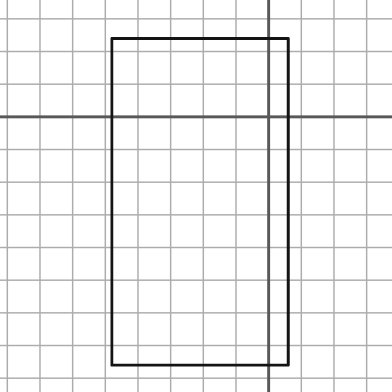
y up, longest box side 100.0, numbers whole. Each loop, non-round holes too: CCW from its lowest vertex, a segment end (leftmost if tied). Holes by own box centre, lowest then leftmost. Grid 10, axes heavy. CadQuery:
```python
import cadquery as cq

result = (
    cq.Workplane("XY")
    .moveTo(-48.0, -76.0)
    .lineTo(6.0, -76.0)
    .lineTo(6.0, 24.0)
    .lineTo(-48.0, 24.0)
    .close()
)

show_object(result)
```